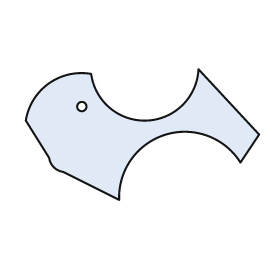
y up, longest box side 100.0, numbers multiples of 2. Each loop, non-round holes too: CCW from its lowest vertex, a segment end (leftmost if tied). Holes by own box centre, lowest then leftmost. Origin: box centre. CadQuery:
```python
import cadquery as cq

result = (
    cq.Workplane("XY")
    .moveTo(-10.0, -28.0)
    .threePointArc((10.0, 0.0), (42.0, -12.0))
    .lineTo(50.0, 0.0)
    .lineTo(24.0, 28.0)
    .threePointArc((2.0, 6.0), (-22.0, 26.0))
    .threePointArc((-40.0, 22.0), (-50.0, 6.0))
    .lineTo(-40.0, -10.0)
    .threePointArc((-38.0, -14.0), (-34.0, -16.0))
    .close()
    .moveTo(-26.0, 12.0)
    .circle(2.0)
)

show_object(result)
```